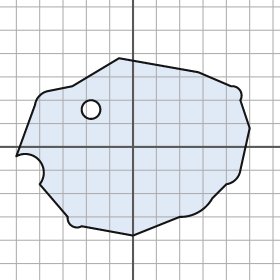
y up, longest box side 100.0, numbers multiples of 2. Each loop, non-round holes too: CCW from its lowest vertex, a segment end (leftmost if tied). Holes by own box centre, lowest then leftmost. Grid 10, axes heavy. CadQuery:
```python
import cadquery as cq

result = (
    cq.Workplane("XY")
    .moveTo(0.0, -38.0)
    .lineTo(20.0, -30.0)
    .threePointArc((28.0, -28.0), (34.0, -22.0))
    .lineTo(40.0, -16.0)
    .threePointArc((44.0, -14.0), (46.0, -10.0))
    .lineTo(50.0, 8.0)
    .lineTo(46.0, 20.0)
    .threePointArc((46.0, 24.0), (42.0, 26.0))
    .lineTo(28.0, 32.0)
    .lineTo(-6.0, 38.0)
    .lineTo(-26.0, 26.0)
    .lineTo(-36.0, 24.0)
    .threePointArc((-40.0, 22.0), (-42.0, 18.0))
    .lineTo(-50.0, -4.0)
    .threePointArc((-40.0, -6.0), (-40.0, -16.0))
    .lineTo(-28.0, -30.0)
    .threePointArc((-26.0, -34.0), (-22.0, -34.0))
    .close()
    .moveTo(-18.0, 16.0)
    .circle(4.0)
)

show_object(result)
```